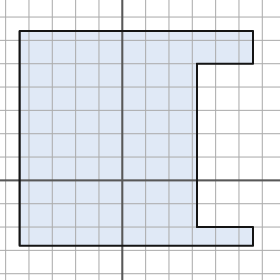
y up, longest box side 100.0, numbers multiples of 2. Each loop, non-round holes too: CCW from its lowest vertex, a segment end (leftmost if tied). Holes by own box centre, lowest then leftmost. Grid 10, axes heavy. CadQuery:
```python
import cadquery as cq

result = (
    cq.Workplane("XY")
    .moveTo(-44.0, -28.0)
    .lineTo(56.0, -28.0)
    .lineTo(56.0, -20.0)
    .lineTo(32.0, -20.0)
    .lineTo(32.0, 50.0)
    .lineTo(56.0, 50.0)
    .lineTo(56.0, 64.0)
    .lineTo(-44.0, 64.0)
    .close()
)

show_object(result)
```